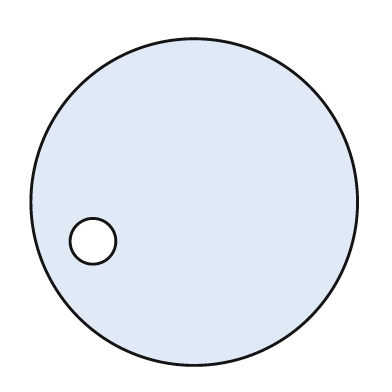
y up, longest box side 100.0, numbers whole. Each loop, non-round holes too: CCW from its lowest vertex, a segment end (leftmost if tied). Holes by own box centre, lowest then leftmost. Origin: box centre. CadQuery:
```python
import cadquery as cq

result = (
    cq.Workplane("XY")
    .moveTo(0.0, 0.0)
    .circle(50.0)
    .moveTo(-31.0, -12.0)
    .circle(7.0)
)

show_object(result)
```